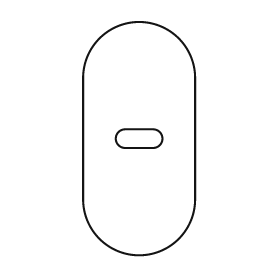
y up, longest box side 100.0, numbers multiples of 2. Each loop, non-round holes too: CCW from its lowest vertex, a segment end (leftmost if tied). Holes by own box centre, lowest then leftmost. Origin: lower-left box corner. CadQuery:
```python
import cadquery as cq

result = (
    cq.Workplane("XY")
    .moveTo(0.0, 24.0)
    .threePointArc((24.0, 0.0), (48.0, 24.0))
    .lineTo(48.0, 76.0)
    .threePointArc((24.0, 100.0), (0.0, 76.0))
    .close()
    .moveTo(18.0, 46.0)
    .lineTo(30.0, 46.0)
    .threePointArc((34.0, 50.0), (30.0, 54.0))
    .lineTo(18.0, 54.0)
    .threePointArc((14.0, 50.0), (18.0, 46.0))
    .close()
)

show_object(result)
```